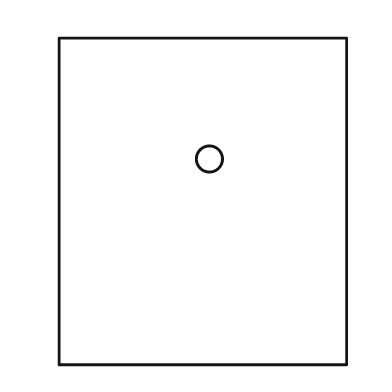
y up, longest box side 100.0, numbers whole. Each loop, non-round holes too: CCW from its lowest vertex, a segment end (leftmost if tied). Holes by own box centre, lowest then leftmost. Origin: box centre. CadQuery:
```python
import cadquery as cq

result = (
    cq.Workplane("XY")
    .moveTo(-44.0, -50.0)
    .lineTo(44.0, -50.0)
    .lineTo(44.0, 50.0)
    .lineTo(-44.0, 50.0)
    .close()
    .moveTo(2.0, 13.0)
    .circle(4.0)
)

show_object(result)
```